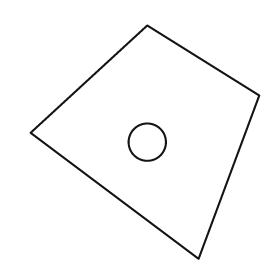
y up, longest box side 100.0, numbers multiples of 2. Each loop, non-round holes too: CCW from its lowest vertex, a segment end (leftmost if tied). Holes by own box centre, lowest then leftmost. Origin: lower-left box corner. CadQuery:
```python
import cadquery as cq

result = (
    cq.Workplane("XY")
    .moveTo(72.0, 0.0)
    .lineTo(98.0, 70.0)
    .lineTo(50.0, 100.0)
    .lineTo(0.0, 54.0)
    .close()
    .moveTo(50.0, 50.0)
    .circle(8.0)
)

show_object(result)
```